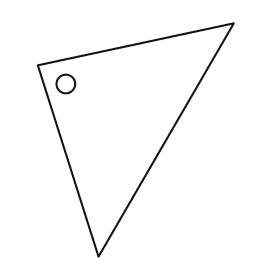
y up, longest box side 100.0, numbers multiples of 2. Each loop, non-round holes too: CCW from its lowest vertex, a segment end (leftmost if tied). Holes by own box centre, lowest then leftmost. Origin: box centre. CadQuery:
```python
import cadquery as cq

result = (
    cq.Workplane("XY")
    .moveTo(-16.0, -50.0)
    .lineTo(42.0, 50.0)
    .lineTo(-42.0, 32.0)
    .close()
    .moveTo(-30.0, 24.0)
    .circle(4.0)
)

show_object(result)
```